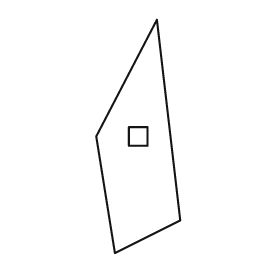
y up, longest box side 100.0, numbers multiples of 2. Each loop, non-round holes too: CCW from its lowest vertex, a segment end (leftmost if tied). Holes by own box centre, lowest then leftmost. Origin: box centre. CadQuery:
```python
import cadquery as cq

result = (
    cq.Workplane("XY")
    .moveTo(-10.0, -50.0)
    .lineTo(18.0, -36.0)
    .lineTo(8.0, 50.0)
    .lineTo(-18.0, 0.0)
    .close()
    .moveTo(-4.0, -4.0)
    .lineTo(4.0, -4.0)
    .lineTo(4.0, 4.0)
    .lineTo(-4.0, 4.0)
    .close()
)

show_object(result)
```